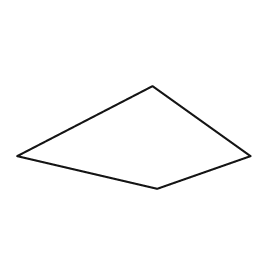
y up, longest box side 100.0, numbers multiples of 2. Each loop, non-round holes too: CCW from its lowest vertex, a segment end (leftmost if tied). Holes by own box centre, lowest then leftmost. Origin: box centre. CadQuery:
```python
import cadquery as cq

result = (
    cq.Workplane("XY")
    .moveTo(10.0, -22.0)
    .lineTo(50.0, -8.0)
    .lineTo(8.0, 22.0)
    .lineTo(-50.0, -8.0)
    .close()
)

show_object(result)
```